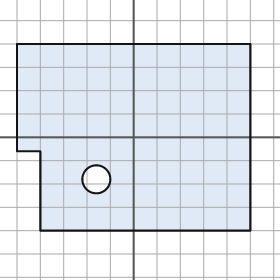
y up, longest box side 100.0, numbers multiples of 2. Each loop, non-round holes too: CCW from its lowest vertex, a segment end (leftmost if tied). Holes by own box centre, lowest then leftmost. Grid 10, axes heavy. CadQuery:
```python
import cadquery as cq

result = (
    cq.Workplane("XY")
    .moveTo(-40.0, -40.0)
    .lineTo(50.0, -40.0)
    .lineTo(50.0, 40.0)
    .lineTo(-50.0, 40.0)
    .lineTo(-50.0, -6.0)
    .lineTo(-40.0, -6.0)
    .close()
    .moveTo(-16.0, -18.0)
    .circle(6.0)
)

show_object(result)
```